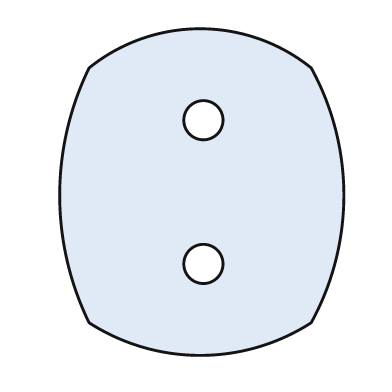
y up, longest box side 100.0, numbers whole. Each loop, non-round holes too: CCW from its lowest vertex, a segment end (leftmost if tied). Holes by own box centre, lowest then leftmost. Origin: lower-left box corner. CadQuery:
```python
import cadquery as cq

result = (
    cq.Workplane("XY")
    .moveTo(9.0, 10.0)
    .threePointArc((43.0, 0.0), (77.0, 10.0))
    .threePointArc((87.0, 49.0), (77.0, 88.0))
    .threePointArc((43.0, 100.0), (9.0, 88.0))
    .threePointArc((0.0, 49.0), (9.0, 10.0))
    .close()
    .moveTo(44.0, 28.0)
    .circle(6.0)
    .moveTo(44.0, 72.0)
    .circle(6.0)
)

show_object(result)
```